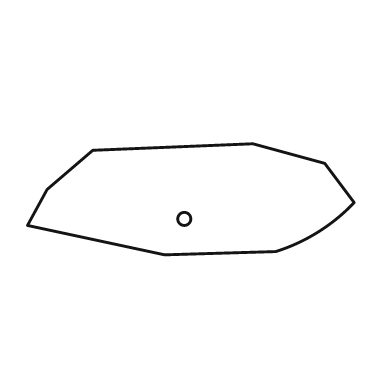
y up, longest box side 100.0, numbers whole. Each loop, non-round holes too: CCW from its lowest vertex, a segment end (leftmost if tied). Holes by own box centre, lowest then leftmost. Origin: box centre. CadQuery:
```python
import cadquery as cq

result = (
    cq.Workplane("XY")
    .moveTo(-8.0, -17.0)
    .lineTo(26.0, -16.0)
    .threePointArc((39.0, -10.0), (50.0, -1.0))
    .lineTo(41.0, 11.0)
    .lineTo(19.0, 17.0)
    .lineTo(-30.0, 15.0)
    .lineTo(-44.0, 3.0)
    .lineTo(-50.0, -8.0)
    .close()
    .moveTo(-2.0, -6.0)
    .circle(2.0)
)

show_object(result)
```